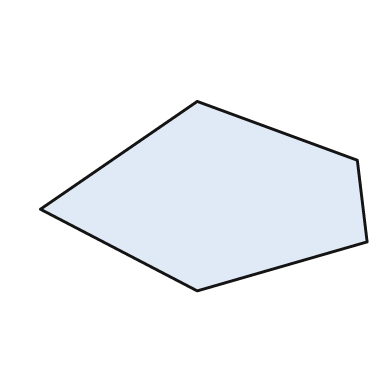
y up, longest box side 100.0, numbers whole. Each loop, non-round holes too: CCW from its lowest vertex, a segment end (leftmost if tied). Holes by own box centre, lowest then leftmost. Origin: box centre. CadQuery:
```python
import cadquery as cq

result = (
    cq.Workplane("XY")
    .moveTo(-2.0, -29.0)
    .lineTo(50.0, -14.0)
    .lineTo(47.0, 11.0)
    .lineTo(-2.0, 29.0)
    .lineTo(-50.0, -4.0)
    .close()
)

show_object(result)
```